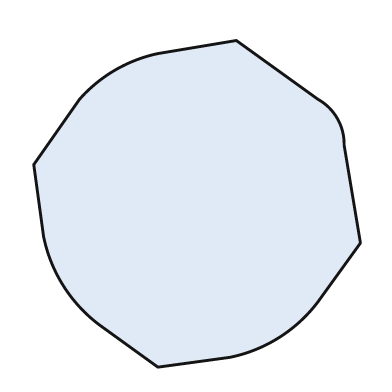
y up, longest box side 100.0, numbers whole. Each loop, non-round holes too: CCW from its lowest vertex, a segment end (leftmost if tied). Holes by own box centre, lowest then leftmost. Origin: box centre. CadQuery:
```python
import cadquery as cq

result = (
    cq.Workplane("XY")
    .moveTo(-12.0, -50.0)
    .lineTo(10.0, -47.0)
    .threePointArc((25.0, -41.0), (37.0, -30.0))
    .lineTo(50.0, -12.0)
    .lineTo(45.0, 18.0)
    .threePointArc((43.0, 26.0), (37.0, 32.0))
    .lineTo(12.0, 50.0)
    .lineTo(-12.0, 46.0)
    .threePointArc((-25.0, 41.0), (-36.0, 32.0))
    .lineTo(-50.0, 12.0)
    .lineTo(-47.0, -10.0)
    .threePointArc((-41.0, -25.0), (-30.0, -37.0))
    .close()
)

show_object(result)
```